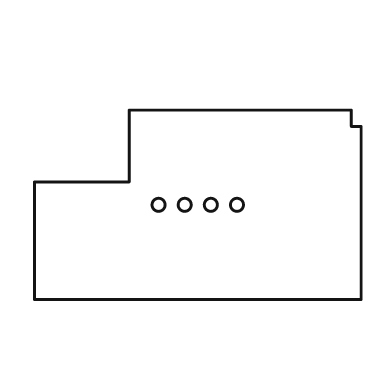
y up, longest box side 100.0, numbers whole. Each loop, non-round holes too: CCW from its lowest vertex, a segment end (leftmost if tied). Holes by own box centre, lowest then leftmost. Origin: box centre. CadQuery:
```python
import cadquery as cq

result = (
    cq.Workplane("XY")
    .moveTo(-50.0, -29.0)
    .lineTo(50.0, -29.0)
    .lineTo(50.0, 24.0)
    .lineTo(47.0, 24.0)
    .lineTo(47.0, 29.0)
    .lineTo(-21.0, 29.0)
    .lineTo(-21.0, 7.0)
    .lineTo(-50.0, 7.0)
    .close()
    .moveTo(-12.0, 0.0)
    .circle(2.0)
    .moveTo(-4.0, 0.0)
    .circle(2.0)
    .moveTo(4.0, 0.0)
    .circle(2.0)
    .moveTo(12.0, 0.0)
    .circle(2.0)
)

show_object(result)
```